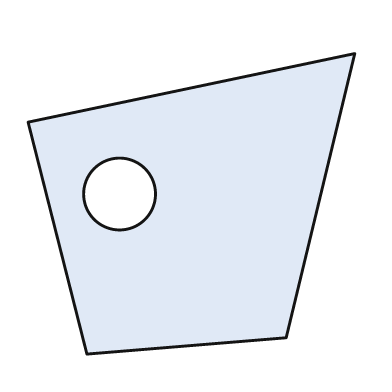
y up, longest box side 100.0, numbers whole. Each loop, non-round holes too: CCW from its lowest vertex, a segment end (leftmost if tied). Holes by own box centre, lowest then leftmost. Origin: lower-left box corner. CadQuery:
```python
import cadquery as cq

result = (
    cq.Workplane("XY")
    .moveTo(18.0, 0.0)
    .lineTo(79.0, 5.0)
    .lineTo(100.0, 92.0)
    .lineTo(0.0, 71.0)
    .close()
    .moveTo(28.0, 49.0)
    .circle(11.0)
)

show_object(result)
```